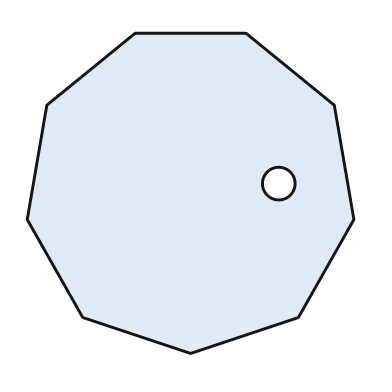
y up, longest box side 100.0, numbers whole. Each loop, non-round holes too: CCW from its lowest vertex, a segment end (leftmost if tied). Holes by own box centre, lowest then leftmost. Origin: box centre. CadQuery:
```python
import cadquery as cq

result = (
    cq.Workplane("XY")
    .moveTo(0.0, -49.0)
    .lineTo(33.0, -38.0)
    .lineTo(50.0, -8.0)
    .lineTo(44.0, 27.0)
    .lineTo(17.0, 49.0)
    .lineTo(-17.0, 49.0)
    .lineTo(-44.0, 27.0)
    .lineTo(-50.0, -8.0)
    .lineTo(-33.0, -38.0)
    .close()
    .moveTo(27.0, 3.0)
    .circle(5.0)
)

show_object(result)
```